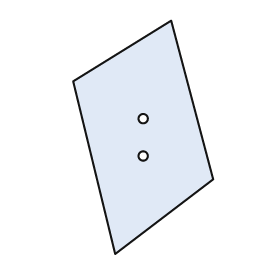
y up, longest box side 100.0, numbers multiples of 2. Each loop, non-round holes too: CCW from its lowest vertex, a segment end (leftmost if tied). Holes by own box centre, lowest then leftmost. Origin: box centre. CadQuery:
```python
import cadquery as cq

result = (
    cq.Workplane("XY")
    .moveTo(-12.0, -50.0)
    .lineTo(30.0, -18.0)
    .lineTo(12.0, 50.0)
    .lineTo(-30.0, 24.0)
    .close()
    .moveTo(0.0, -8.0)
    .circle(2.0)
    .moveTo(0.0, 8.0)
    .circle(2.0)
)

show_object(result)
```